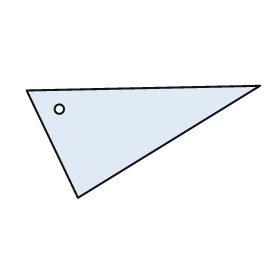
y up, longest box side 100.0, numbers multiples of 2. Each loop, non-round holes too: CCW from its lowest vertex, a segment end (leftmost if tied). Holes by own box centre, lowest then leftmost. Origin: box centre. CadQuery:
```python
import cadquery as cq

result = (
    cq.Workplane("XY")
    .moveTo(-28.0, -24.0)
    .lineTo(50.0, 24.0)
    .lineTo(-50.0, 22.0)
    .close()
    .moveTo(-36.0, 14.0)
    .circle(2.0)
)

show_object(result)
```